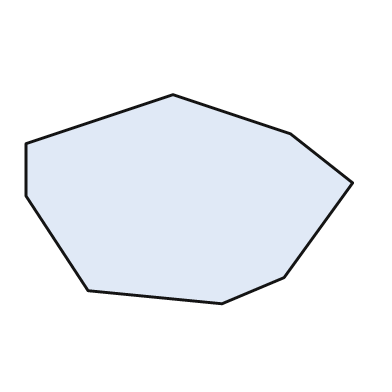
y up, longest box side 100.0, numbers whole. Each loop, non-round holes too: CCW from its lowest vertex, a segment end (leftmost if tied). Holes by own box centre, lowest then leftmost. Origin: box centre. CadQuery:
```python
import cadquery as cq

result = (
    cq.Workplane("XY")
    .moveTo(10.0, -32.0)
    .lineTo(29.0, -24.0)
    .lineTo(50.0, 5.0)
    .lineTo(31.0, 20.0)
    .lineTo(-5.0, 32.0)
    .lineTo(-50.0, 17.0)
    .lineTo(-50.0, 1.0)
    .lineTo(-31.0, -28.0)
    .close()
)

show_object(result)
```